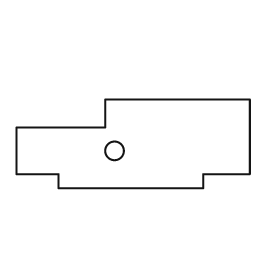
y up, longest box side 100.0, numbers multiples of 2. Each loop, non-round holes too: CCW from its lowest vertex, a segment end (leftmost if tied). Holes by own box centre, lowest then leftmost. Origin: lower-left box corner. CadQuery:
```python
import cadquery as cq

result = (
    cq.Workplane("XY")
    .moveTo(18.0, 0.0)
    .lineTo(80.0, 0.0)
    .lineTo(80.0, 6.0)
    .lineTo(100.0, 6.0)
    .lineTo(100.0, 38.0)
    .lineTo(38.0, 38.0)
    .lineTo(38.0, 26.0)
    .lineTo(0.0, 26.0)
    .lineTo(0.0, 6.0)
    .lineTo(18.0, 6.0)
    .close()
    .moveTo(42.0, 16.0)
    .circle(4.0)
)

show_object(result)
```